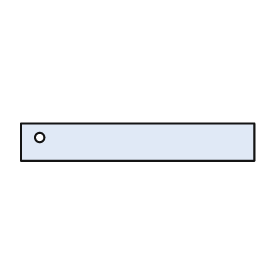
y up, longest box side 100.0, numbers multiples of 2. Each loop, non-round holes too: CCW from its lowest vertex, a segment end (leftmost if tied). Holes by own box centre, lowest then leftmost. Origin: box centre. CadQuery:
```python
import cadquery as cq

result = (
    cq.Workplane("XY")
    .moveTo(-50.0, -8.0)
    .lineTo(50.0, -8.0)
    .lineTo(50.0, 8.0)
    .lineTo(-50.0, 8.0)
    .close()
    .moveTo(-42.0, 2.0)
    .circle(2.0)
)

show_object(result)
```